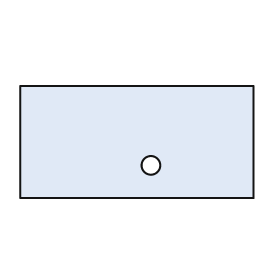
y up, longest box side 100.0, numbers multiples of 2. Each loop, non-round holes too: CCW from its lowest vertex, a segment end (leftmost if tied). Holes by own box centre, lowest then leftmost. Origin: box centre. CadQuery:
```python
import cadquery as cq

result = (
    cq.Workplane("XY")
    .moveTo(-50.0, -24.0)
    .lineTo(50.0, -24.0)
    .lineTo(50.0, 24.0)
    .lineTo(-50.0, 24.0)
    .close()
    .moveTo(6.0, -10.0)
    .circle(4.0)
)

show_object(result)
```